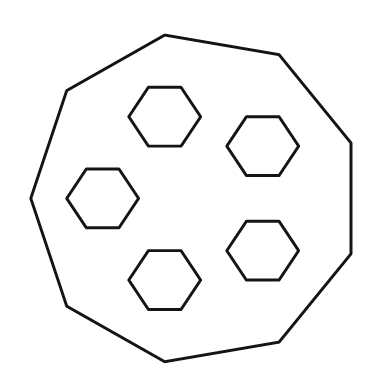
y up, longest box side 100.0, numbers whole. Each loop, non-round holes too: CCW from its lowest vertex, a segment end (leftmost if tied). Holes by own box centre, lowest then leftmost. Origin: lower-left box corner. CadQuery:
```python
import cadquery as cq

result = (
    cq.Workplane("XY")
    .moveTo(41.0, 0.0)
    .lineTo(76.0, 6.0)
    .lineTo(98.0, 33.0)
    .lineTo(98.0, 67.0)
    .lineTo(76.0, 94.0)
    .lineTo(41.0, 100.0)
    .lineTo(11.0, 83.0)
    .lineTo(0.0, 50.0)
    .lineTo(11.0, 17.0)
    .close()
    .moveTo(36.0, 16.0)
    .lineTo(46.0, 16.0)
    .lineTo(52.0, 25.0)
    .lineTo(46.0, 34.0)
    .lineTo(36.0, 34.0)
    .lineTo(30.0, 25.0)
    .close()
    .moveTo(66.0, 25.0)
    .lineTo(76.0, 25.0)
    .lineTo(82.0, 34.0)
    .lineTo(76.0, 43.0)
    .lineTo(66.0, 43.0)
    .lineTo(60.0, 34.0)
    .close()
    .moveTo(17.0, 41.0)
    .lineTo(27.0, 41.0)
    .lineTo(33.0, 50.0)
    .lineTo(27.0, 59.0)
    .lineTo(17.0, 59.0)
    .lineTo(11.0, 50.0)
    .close()
    .moveTo(66.0, 57.0)
    .lineTo(76.0, 57.0)
    .lineTo(82.0, 66.0)
    .lineTo(76.0, 75.0)
    .lineTo(66.0, 75.0)
    .lineTo(60.0, 66.0)
    .close()
    .moveTo(36.0, 66.0)
    .lineTo(46.0, 66.0)
    .lineTo(52.0, 75.0)
    .lineTo(46.0, 84.0)
    .lineTo(36.0, 84.0)
    .lineTo(30.0, 75.0)
    .close()
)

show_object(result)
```